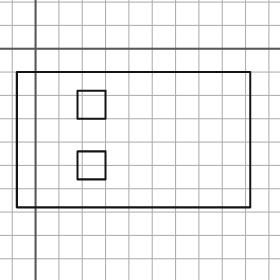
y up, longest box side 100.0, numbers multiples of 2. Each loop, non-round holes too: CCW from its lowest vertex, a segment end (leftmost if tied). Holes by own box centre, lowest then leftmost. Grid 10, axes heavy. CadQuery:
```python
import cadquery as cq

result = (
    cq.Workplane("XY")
    .moveTo(-8.0, -68.0)
    .lineTo(92.0, -68.0)
    .lineTo(92.0, -10.0)
    .lineTo(-8.0, -10.0)
    .close()
    .moveTo(18.0, -56.0)
    .lineTo(30.0, -56.0)
    .lineTo(30.0, -44.0)
    .lineTo(18.0, -44.0)
    .close()
    .moveTo(18.0, -30.0)
    .lineTo(30.0, -30.0)
    .lineTo(30.0, -18.0)
    .lineTo(18.0, -18.0)
    .close()
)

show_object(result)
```